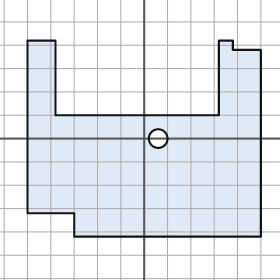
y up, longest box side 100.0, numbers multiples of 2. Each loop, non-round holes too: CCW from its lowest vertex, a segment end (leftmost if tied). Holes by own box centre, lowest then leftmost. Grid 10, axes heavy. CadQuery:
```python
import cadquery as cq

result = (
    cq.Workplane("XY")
    .moveTo(-30.0, -42.0)
    .lineTo(50.0, -42.0)
    .lineTo(50.0, 38.0)
    .lineTo(38.0, 38.0)
    .lineTo(38.0, 42.0)
    .lineTo(32.0, 42.0)
    .lineTo(32.0, 10.0)
    .lineTo(-38.0, 10.0)
    .lineTo(-38.0, 42.0)
    .lineTo(-50.0, 42.0)
    .lineTo(-50.0, -32.0)
    .lineTo(-30.0, -32.0)
    .close()
    .moveTo(6.0, 0.0)
    .circle(4.0)
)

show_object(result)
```